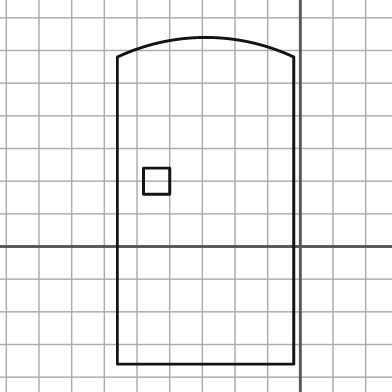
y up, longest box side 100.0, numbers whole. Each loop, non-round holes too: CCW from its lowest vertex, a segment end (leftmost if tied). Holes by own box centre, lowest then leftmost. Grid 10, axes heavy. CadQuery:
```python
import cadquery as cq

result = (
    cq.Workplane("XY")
    .moveTo(-56.0, -36.0)
    .lineTo(-2.0, -36.0)
    .lineTo(-2.0, 58.0)
    .threePointArc((-29.0, 64.0), (-56.0, 58.0))
    .close()
    .moveTo(-48.0, 16.0)
    .lineTo(-40.0, 16.0)
    .lineTo(-40.0, 24.0)
    .lineTo(-48.0, 24.0)
    .close()
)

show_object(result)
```